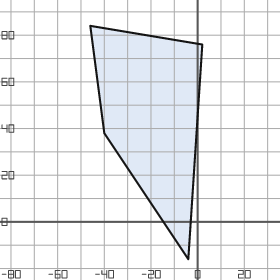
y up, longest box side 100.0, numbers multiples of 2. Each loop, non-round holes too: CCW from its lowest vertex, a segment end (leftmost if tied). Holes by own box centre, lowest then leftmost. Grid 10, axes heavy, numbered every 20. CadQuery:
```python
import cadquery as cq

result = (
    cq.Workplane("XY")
    .moveTo(-4.0, -16.0)
    .lineTo(2.0, 76.0)
    .lineTo(-46.0, 84.0)
    .lineTo(-40.0, 38.0)
    .close()
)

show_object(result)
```